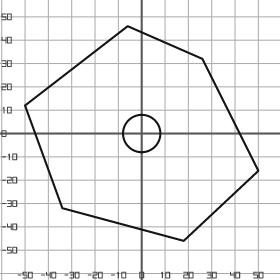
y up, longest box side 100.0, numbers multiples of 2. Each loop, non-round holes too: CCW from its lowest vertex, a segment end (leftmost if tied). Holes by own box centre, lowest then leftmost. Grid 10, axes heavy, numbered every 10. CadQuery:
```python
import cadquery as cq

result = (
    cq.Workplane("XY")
    .moveTo(18.0, -46.0)
    .lineTo(50.0, -16.0)
    .lineTo(26.0, 32.0)
    .lineTo(-6.0, 46.0)
    .lineTo(-50.0, 12.0)
    .lineTo(-34.0, -32.0)
    .close()
    .moveTo(0.0, 0.0)
    .circle(8.0)
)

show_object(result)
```